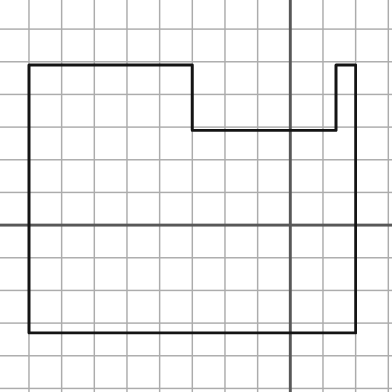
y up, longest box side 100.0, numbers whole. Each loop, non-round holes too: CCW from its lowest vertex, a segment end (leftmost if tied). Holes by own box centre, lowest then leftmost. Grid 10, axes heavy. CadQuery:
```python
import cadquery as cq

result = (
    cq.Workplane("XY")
    .moveTo(-80.0, -33.0)
    .lineTo(20.0, -33.0)
    .lineTo(20.0, 49.0)
    .lineTo(14.0, 49.0)
    .lineTo(14.0, 29.0)
    .lineTo(-30.0, 29.0)
    .lineTo(-30.0, 49.0)
    .lineTo(-80.0, 49.0)
    .close()
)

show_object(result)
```